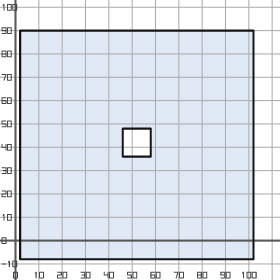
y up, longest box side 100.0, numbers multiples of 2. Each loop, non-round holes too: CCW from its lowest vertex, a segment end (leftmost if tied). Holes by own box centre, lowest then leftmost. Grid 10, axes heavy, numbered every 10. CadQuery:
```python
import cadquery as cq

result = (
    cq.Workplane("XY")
    .moveTo(2.0, -8.0)
    .lineTo(102.0, -8.0)
    .lineTo(102.0, 90.0)
    .lineTo(2.0, 90.0)
    .close()
    .moveTo(46.0, 36.0)
    .lineTo(58.0, 36.0)
    .lineTo(58.0, 48.0)
    .lineTo(46.0, 48.0)
    .close()
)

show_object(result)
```